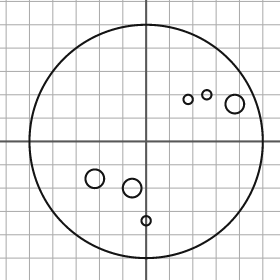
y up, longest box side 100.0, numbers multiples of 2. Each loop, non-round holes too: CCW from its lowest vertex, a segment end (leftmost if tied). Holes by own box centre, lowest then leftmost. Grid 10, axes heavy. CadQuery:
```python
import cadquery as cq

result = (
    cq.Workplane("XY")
    .moveTo(0.0, 0.0)
    .circle(50.0)
    .moveTo(0.0, -34.0)
    .circle(2.0)
    .moveTo(-6.0, -20.0)
    .circle(4.0)
    .moveTo(-22.0, -16.0)
    .circle(4.0)
    .moveTo(38.0, 16.0)
    .circle(4.0)
    .moveTo(18.0, 18.0)
    .circle(2.0)
    .moveTo(26.0, 20.0)
    .circle(2.0)
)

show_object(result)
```